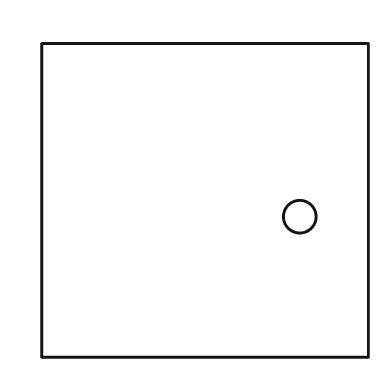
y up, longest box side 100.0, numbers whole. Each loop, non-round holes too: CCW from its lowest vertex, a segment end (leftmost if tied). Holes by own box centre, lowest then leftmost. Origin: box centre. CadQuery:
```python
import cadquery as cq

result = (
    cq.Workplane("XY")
    .moveTo(-50.0, -48.0)
    .lineTo(50.0, -48.0)
    .lineTo(50.0, 48.0)
    .lineTo(-50.0, 48.0)
    .close()
    .moveTo(29.0, -5.0)
    .circle(5.0)
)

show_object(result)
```